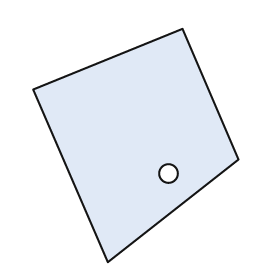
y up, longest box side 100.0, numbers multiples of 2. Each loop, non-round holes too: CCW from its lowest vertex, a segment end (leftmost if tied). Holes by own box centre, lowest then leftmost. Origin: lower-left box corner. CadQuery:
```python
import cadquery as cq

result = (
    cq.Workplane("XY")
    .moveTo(32.0, 0.0)
    .lineTo(88.0, 44.0)
    .lineTo(64.0, 100.0)
    .lineTo(0.0, 74.0)
    .close()
    .moveTo(58.0, 38.0)
    .circle(4.0)
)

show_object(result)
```